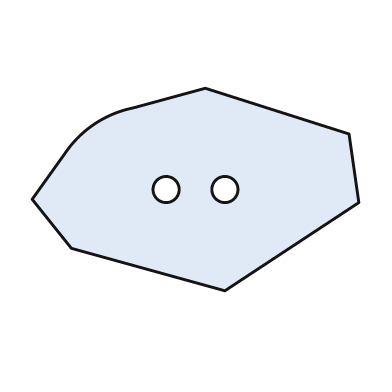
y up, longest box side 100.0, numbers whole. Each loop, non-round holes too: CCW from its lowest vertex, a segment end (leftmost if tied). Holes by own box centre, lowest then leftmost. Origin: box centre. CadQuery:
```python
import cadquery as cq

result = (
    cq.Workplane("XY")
    .moveTo(9.0, -31.0)
    .lineTo(50.0, -4.0)
    .lineTo(47.0, 17.0)
    .lineTo(3.0, 31.0)
    .lineTo(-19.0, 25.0)
    .threePointArc((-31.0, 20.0), (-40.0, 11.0))
    .lineTo(-50.0, -3.0)
    .lineTo(-38.0, -18.0)
    .close()
    .moveTo(-9.0, 0.0)
    .circle(4.0)
    .moveTo(9.0, 0.0)
    .circle(4.0)
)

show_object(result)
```